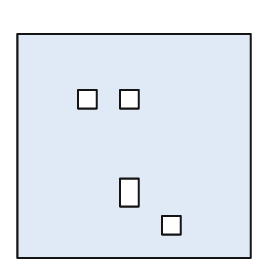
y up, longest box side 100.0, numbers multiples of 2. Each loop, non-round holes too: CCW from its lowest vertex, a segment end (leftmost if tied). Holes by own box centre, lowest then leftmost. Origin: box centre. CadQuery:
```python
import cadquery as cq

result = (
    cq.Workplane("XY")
    .moveTo(-50.0, -48.0)
    .lineTo(50.0, -48.0)
    .lineTo(50.0, 48.0)
    .lineTo(-50.0, 48.0)
    .close()
    .moveTo(12.0, -38.0)
    .lineTo(20.0, -38.0)
    .lineTo(20.0, -30.0)
    .lineTo(12.0, -30.0)
    .close()
    .moveTo(-6.0, -26.0)
    .lineTo(2.0, -26.0)
    .lineTo(2.0, -14.0)
    .lineTo(-6.0, -14.0)
    .close()
    .moveTo(-24.0, 16.0)
    .lineTo(-16.0, 16.0)
    .lineTo(-16.0, 24.0)
    .lineTo(-24.0, 24.0)
    .close()
    .moveTo(-6.0, 16.0)
    .lineTo(2.0, 16.0)
    .lineTo(2.0, 24.0)
    .lineTo(-6.0, 24.0)
    .close()
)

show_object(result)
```